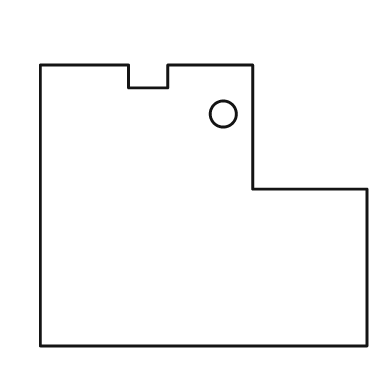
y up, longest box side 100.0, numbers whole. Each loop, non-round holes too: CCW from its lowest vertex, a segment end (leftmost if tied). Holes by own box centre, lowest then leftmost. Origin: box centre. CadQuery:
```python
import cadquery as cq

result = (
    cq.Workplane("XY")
    .moveTo(-50.0, -43.0)
    .lineTo(50.0, -43.0)
    .lineTo(50.0, 5.0)
    .lineTo(15.0, 5.0)
    .lineTo(15.0, 43.0)
    .lineTo(-11.0, 43.0)
    .lineTo(-11.0, 36.0)
    .lineTo(-23.0, 36.0)
    .lineTo(-23.0, 43.0)
    .lineTo(-50.0, 43.0)
    .close()
    .moveTo(6.0, 28.0)
    .circle(4.0)
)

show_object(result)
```